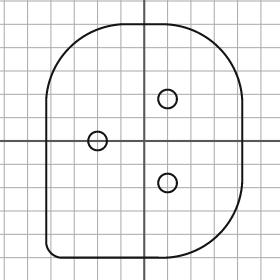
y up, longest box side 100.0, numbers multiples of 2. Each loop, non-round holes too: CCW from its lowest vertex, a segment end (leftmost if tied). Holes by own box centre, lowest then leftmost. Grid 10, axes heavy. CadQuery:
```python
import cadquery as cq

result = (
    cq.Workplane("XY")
    .moveTo(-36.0, -50.0)
    .lineTo(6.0, -50.0)
    .threePointArc((32.0, -40.0), (42.0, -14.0))
    .lineTo(42.0, 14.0)
    .threePointArc((32.0, 40.0), (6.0, 50.0))
    .lineTo(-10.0, 50.0)
    .threePointArc((-32.0, 40.0), (-42.0, 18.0))
    .lineTo(-42.0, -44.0)
    .threePointArc((-40.0, -48.0), (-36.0, -50.0))
    .close()
    .moveTo(10.0, -18.0)
    .circle(4.0)
    .moveTo(-20.0, 0.0)
    .circle(4.0)
    .moveTo(10.0, 18.0)
    .circle(4.0)
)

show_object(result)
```